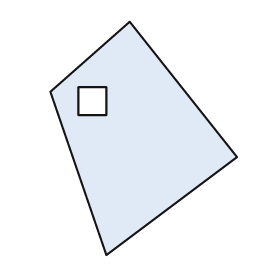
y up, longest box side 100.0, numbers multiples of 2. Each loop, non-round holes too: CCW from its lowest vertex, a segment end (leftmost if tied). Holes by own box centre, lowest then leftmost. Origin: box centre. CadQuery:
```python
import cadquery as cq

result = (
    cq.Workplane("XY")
    .moveTo(-16.0, -50.0)
    .lineTo(40.0, -8.0)
    .lineTo(-6.0, 50.0)
    .lineTo(-40.0, 20.0)
    .close()
    .moveTo(-28.0, 10.0)
    .lineTo(-16.0, 10.0)
    .lineTo(-16.0, 22.0)
    .lineTo(-28.0, 22.0)
    .close()
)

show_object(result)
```